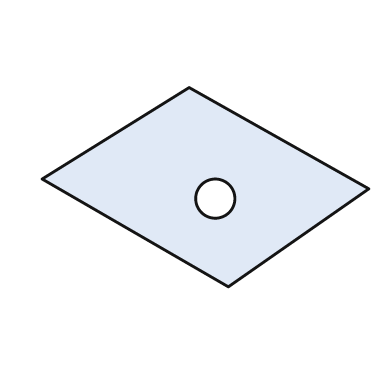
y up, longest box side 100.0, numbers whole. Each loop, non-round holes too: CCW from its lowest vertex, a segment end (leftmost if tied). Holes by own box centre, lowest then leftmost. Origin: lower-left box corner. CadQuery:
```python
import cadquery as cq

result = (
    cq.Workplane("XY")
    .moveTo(57.0, 0.0)
    .lineTo(100.0, 30.0)
    .lineTo(45.0, 61.0)
    .lineTo(0.0, 33.0)
    .close()
    .moveTo(53.0, 27.0)
    .circle(6.0)
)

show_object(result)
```